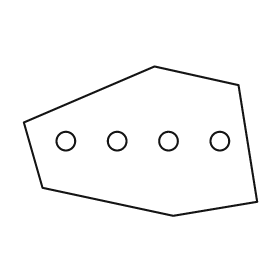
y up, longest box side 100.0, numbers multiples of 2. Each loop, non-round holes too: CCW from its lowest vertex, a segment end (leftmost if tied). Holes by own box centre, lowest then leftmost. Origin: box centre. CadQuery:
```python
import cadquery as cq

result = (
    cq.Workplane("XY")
    .moveTo(14.0, -32.0)
    .lineTo(50.0, -26.0)
    .lineTo(42.0, 24.0)
    .lineTo(6.0, 32.0)
    .lineTo(-50.0, 8.0)
    .lineTo(-42.0, -20.0)
    .close()
    .moveTo(-32.0, 0.0)
    .circle(4.0)
    .moveTo(-10.0, 0.0)
    .circle(4.0)
    .moveTo(12.0, 0.0)
    .circle(4.0)
    .moveTo(34.0, 0.0)
    .circle(4.0)
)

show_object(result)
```